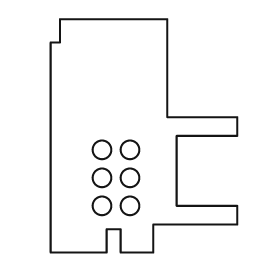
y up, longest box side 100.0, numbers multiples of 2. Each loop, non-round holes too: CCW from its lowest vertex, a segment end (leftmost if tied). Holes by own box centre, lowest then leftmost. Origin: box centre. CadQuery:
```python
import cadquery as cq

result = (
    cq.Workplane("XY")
    .moveTo(-40.0, -50.0)
    .lineTo(-16.0, -50.0)
    .lineTo(-16.0, -40.0)
    .lineTo(-10.0, -40.0)
    .lineTo(-10.0, -50.0)
    .lineTo(4.0, -50.0)
    .lineTo(4.0, -38.0)
    .lineTo(40.0, -38.0)
    .lineTo(40.0, -30.0)
    .lineTo(14.0, -30.0)
    .lineTo(14.0, 0.0)
    .lineTo(40.0, 0.0)
    .lineTo(40.0, 8.0)
    .lineTo(10.0, 8.0)
    .lineTo(10.0, 50.0)
    .lineTo(-36.0, 50.0)
    .lineTo(-36.0, 40.0)
    .lineTo(-40.0, 40.0)
    .close()
    .moveTo(-18.0, -30.0)
    .circle(4.0)
    .moveTo(-6.0, -30.0)
    .circle(4.0)
    .moveTo(-18.0, -18.0)
    .circle(4.0)
    .moveTo(-6.0, -18.0)
    .circle(4.0)
    .moveTo(-18.0, -6.0)
    .circle(4.0)
    .moveTo(-6.0, -6.0)
    .circle(4.0)
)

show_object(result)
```